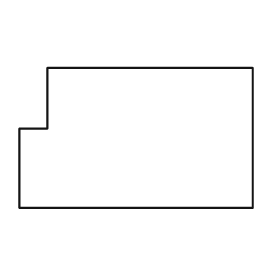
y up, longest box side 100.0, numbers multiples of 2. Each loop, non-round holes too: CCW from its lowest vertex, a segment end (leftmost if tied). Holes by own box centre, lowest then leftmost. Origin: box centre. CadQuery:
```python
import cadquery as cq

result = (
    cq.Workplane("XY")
    .moveTo(-50.0, -30.0)
    .lineTo(50.0, -30.0)
    .lineTo(50.0, 30.0)
    .lineTo(-38.0, 30.0)
    .lineTo(-38.0, 4.0)
    .lineTo(-50.0, 4.0)
    .close()
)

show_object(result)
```